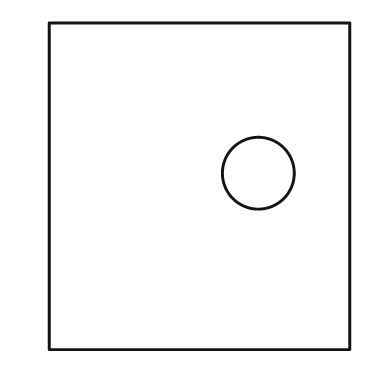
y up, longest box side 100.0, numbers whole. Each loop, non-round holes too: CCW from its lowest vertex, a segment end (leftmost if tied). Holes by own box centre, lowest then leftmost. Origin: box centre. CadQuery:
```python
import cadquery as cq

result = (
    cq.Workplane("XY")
    .moveTo(-46.0, -50.0)
    .lineTo(46.0, -50.0)
    .lineTo(46.0, 50.0)
    .lineTo(-46.0, 50.0)
    .close()
    .moveTo(18.0, 4.0)
    .circle(11.0)
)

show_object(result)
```